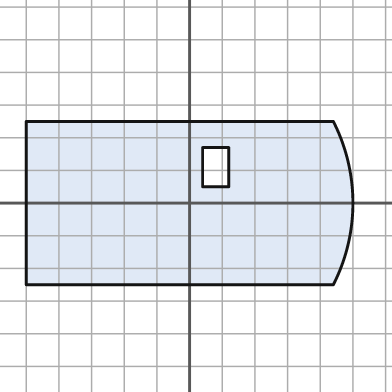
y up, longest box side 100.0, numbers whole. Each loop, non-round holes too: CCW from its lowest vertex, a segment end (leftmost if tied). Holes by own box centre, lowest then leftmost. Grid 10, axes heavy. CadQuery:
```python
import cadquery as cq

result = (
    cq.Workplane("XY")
    .moveTo(-50.0, -25.0)
    .lineTo(44.0, -25.0)
    .threePointArc((50.0, 0.0), (44.0, 25.0))
    .lineTo(-50.0, 25.0)
    .close()
    .moveTo(4.0, 5.0)
    .lineTo(12.0, 5.0)
    .lineTo(12.0, 17.0)
    .lineTo(4.0, 17.0)
    .close()
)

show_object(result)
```